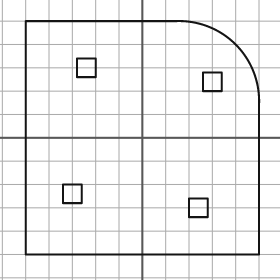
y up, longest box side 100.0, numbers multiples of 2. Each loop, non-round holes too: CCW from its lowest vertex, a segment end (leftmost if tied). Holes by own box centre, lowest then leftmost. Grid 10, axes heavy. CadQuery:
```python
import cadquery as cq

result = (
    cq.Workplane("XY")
    .moveTo(-50.0, -50.0)
    .lineTo(50.0, -50.0)
    .lineTo(50.0, 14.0)
    .threePointArc((40.0, 40.0), (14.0, 50.0))
    .lineTo(-50.0, 50.0)
    .close()
    .moveTo(20.0, -34.0)
    .lineTo(28.0, -34.0)
    .lineTo(28.0, -26.0)
    .lineTo(20.0, -26.0)
    .close()
    .moveTo(-34.0, -28.0)
    .lineTo(-26.0, -28.0)
    .lineTo(-26.0, -20.0)
    .lineTo(-34.0, -20.0)
    .close()
    .moveTo(26.0, 20.0)
    .lineTo(34.0, 20.0)
    .lineTo(34.0, 28.0)
    .lineTo(26.0, 28.0)
    .close()
    .moveTo(-28.0, 26.0)
    .lineTo(-20.0, 26.0)
    .lineTo(-20.0, 34.0)
    .lineTo(-28.0, 34.0)
    .close()
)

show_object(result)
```